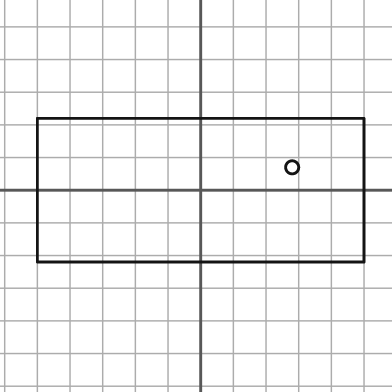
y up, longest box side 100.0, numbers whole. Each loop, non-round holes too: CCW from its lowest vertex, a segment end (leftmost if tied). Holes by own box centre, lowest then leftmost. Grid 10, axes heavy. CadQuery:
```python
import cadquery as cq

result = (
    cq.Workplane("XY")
    .moveTo(-50.0, -22.0)
    .lineTo(50.0, -22.0)
    .lineTo(50.0, 22.0)
    .lineTo(-50.0, 22.0)
    .close()
    .moveTo(28.0, 7.0)
    .circle(2.0)
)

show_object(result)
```